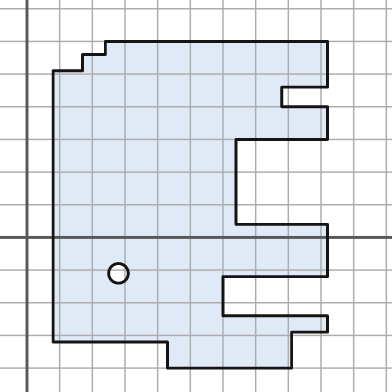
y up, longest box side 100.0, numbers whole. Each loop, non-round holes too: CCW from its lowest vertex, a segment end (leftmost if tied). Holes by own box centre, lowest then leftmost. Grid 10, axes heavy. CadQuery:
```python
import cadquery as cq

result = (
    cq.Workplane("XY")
    .moveTo(43.0, -40.0)
    .lineTo(81.0, -40.0)
    .lineTo(81.0, -29.0)
    .lineTo(92.0, -29.0)
    .lineTo(92.0, -24.0)
    .lineTo(60.0, -24.0)
    .lineTo(60.0, -12.0)
    .lineTo(92.0, -12.0)
    .lineTo(92.0, 4.0)
    .lineTo(64.0, 4.0)
    .lineTo(64.0, 30.0)
    .lineTo(92.0, 30.0)
    .lineTo(92.0, 40.0)
    .lineTo(78.0, 40.0)
    .lineTo(78.0, 46.0)
    .lineTo(92.0, 46.0)
    .lineTo(92.0, 60.0)
    .lineTo(24.0, 60.0)
    .lineTo(24.0, 56.0)
    .lineTo(17.0, 56.0)
    .lineTo(17.0, 51.0)
    .lineTo(8.0, 51.0)
    .lineTo(8.0, -32.0)
    .lineTo(43.0, -32.0)
    .close()
    .moveTo(28.0, -11.0)
    .circle(3.0)
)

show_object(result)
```